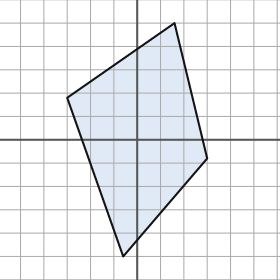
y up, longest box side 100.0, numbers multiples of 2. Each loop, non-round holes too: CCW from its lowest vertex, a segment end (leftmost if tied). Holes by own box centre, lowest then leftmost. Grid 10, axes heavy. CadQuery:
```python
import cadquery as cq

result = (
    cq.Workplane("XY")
    .moveTo(-6.0, -50.0)
    .lineTo(30.0, -8.0)
    .lineTo(16.0, 50.0)
    .lineTo(-30.0, 18.0)
    .close()
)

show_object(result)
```